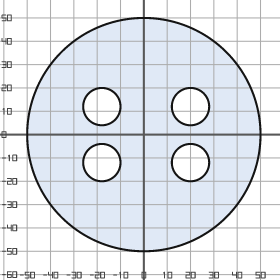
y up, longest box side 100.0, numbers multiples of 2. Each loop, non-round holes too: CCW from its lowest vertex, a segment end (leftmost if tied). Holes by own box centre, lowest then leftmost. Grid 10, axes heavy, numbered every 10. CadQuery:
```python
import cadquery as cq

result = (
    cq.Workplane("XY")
    .moveTo(0.0, 0.0)
    .circle(50.0)
    .moveTo(-18.0, -12.0)
    .circle(8.0)
    .moveTo(20.0, -12.0)
    .circle(8.0)
    .moveTo(-18.0, 12.0)
    .circle(8.0)
    .moveTo(20.0, 12.0)
    .circle(8.0)
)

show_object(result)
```